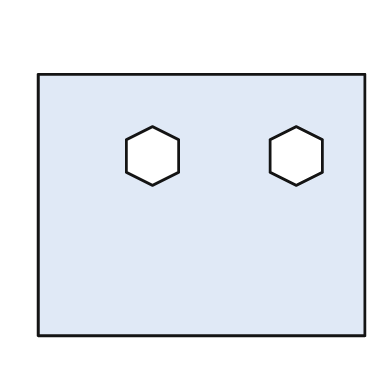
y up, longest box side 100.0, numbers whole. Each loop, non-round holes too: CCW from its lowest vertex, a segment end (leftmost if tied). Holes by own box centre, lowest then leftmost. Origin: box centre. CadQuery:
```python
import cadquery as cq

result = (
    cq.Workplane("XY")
    .moveTo(-50.0, -40.0)
    .lineTo(50.0, -40.0)
    .lineTo(50.0, 40.0)
    .lineTo(-50.0, 40.0)
    .close()
    .moveTo(-15.0, 6.0)
    .lineTo(-7.0, 10.0)
    .lineTo(-7.0, 20.0)
    .lineTo(-15.0, 24.0)
    .lineTo(-23.0, 20.0)
    .lineTo(-23.0, 10.0)
    .close()
    .moveTo(29.0, 6.0)
    .lineTo(37.0, 10.0)
    .lineTo(37.0, 20.0)
    .lineTo(29.0, 24.0)
    .lineTo(21.0, 20.0)
    .lineTo(21.0, 10.0)
    .close()
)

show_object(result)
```